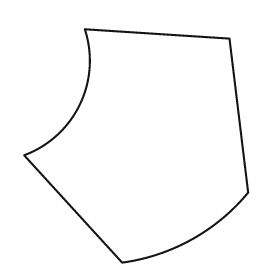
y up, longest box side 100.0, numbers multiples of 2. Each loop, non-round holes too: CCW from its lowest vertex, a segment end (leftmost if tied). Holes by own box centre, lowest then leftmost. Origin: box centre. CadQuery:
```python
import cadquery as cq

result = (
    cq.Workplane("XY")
    .moveTo(-6.0, -50.0)
    .threePointArc((24.0, -40.0), (48.0, -20.0))
    .lineTo(40.0, 46.0)
    .lineTo(-22.0, 50.0)
    .threePointArc((-24.0, 18.0), (-48.0, -4.0))
    .close()
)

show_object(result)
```